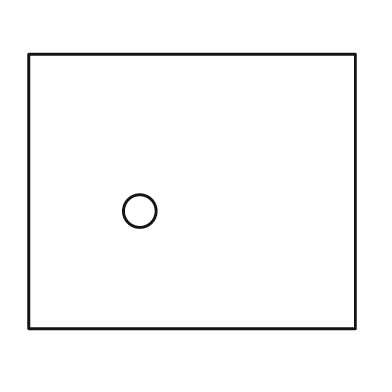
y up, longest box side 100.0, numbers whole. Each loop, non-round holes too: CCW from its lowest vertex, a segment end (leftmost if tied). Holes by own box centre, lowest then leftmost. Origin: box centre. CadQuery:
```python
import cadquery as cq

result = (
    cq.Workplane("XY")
    .moveTo(-50.0, -42.0)
    .lineTo(50.0, -42.0)
    .lineTo(50.0, 42.0)
    .lineTo(-50.0, 42.0)
    .close()
    .moveTo(-16.0, -6.0)
    .circle(5.0)
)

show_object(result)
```